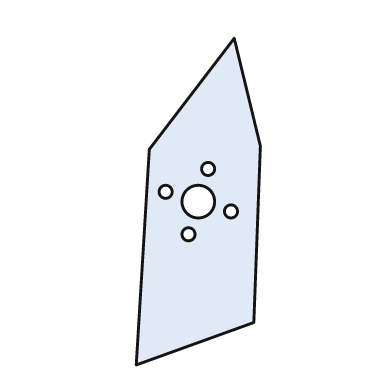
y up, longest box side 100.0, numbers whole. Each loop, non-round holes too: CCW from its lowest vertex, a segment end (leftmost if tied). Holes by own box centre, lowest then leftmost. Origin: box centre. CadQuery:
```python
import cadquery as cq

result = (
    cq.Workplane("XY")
    .moveTo(-19.0, -50.0)
    .lineTo(17.0, -37.0)
    .lineTo(19.0, 17.0)
    .lineTo(11.0, 50.0)
    .lineTo(-15.0, 16.0)
    .close()
    .moveTo(-3.0, -10.0)
    .circle(2.0)
    .moveTo(10.0, -3.0)
    .circle(2.0)
    .moveTo(0.0, 0.0)
    .circle(5.0)
    .moveTo(-10.0, 3.0)
    .circle(2.0)
    .moveTo(3.0, 10.0)
    .circle(2.0)
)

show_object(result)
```